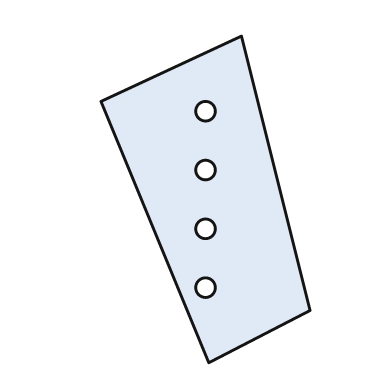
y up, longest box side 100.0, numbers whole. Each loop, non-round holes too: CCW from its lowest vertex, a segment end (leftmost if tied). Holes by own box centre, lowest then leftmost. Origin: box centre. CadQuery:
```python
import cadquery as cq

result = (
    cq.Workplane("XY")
    .moveTo(1.0, -50.0)
    .lineTo(32.0, -34.0)
    .lineTo(11.0, 50.0)
    .lineTo(-32.0, 30.0)
    .close()
    .moveTo(0.0, -27.0)
    .circle(3.0)
    .moveTo(0.0, -9.0)
    .circle(3.0)
    .moveTo(0.0, 9.0)
    .circle(3.0)
    .moveTo(0.0, 27.0)
    .circle(3.0)
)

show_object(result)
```